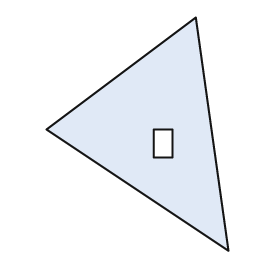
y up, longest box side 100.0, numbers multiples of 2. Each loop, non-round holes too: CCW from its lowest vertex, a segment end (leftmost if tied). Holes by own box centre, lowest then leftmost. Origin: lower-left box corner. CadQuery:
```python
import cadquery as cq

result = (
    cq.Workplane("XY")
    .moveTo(78.0, 0.0)
    .lineTo(64.0, 100.0)
    .lineTo(0.0, 52.0)
    .close()
    .moveTo(46.0, 40.0)
    .lineTo(54.0, 40.0)
    .lineTo(54.0, 52.0)
    .lineTo(46.0, 52.0)
    .close()
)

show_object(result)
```